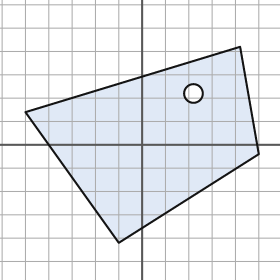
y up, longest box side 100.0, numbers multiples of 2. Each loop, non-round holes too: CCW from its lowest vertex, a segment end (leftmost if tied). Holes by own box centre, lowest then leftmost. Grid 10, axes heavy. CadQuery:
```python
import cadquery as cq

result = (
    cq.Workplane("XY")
    .moveTo(-10.0, -42.0)
    .lineTo(50.0, -4.0)
    .lineTo(42.0, 42.0)
    .lineTo(-50.0, 14.0)
    .close()
    .moveTo(22.0, 22.0)
    .circle(4.0)
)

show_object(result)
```